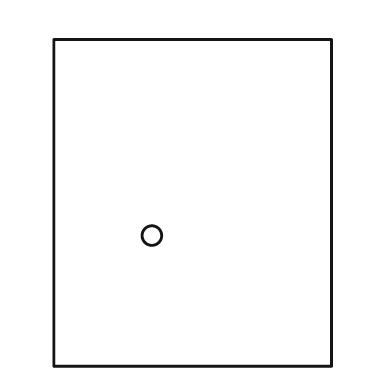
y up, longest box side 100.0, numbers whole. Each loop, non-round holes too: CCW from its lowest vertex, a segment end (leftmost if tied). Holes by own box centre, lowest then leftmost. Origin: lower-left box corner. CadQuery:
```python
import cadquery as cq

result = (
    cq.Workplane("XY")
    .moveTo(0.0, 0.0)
    .lineTo(85.0, 0.0)
    .lineTo(85.0, 100.0)
    .lineTo(0.0, 100.0)
    .close()
    .moveTo(30.0, 40.0)
    .circle(3.0)
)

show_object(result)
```